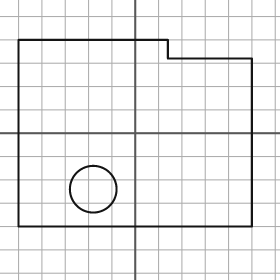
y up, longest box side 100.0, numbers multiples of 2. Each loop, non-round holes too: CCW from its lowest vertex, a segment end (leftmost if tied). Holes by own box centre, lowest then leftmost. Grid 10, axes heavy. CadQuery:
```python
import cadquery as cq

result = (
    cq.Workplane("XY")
    .moveTo(-50.0, -40.0)
    .lineTo(50.0, -40.0)
    .lineTo(50.0, 32.0)
    .lineTo(14.0, 32.0)
    .lineTo(14.0, 40.0)
    .lineTo(-50.0, 40.0)
    .close()
    .moveTo(-18.0, -24.0)
    .circle(10.0)
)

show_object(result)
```